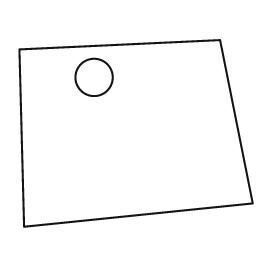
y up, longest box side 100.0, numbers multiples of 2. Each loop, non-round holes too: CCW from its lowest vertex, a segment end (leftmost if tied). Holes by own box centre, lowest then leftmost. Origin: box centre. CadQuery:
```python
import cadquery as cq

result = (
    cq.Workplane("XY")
    .moveTo(-48.0, -40.0)
    .lineTo(50.0, -30.0)
    .lineTo(36.0, 40.0)
    .lineTo(-50.0, 36.0)
    .close()
    .moveTo(-18.0, 24.0)
    .circle(8.0)
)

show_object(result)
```